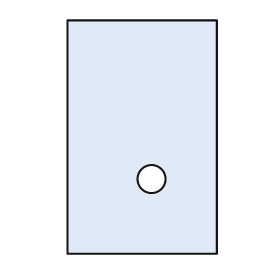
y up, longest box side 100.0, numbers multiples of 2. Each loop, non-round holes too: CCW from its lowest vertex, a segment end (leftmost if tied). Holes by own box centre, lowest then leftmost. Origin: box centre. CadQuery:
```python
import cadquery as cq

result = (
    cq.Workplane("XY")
    .moveTo(-32.0, -50.0)
    .lineTo(32.0, -50.0)
    .lineTo(32.0, 50.0)
    .lineTo(-32.0, 50.0)
    .close()
    .moveTo(4.0, -18.0)
    .circle(6.0)
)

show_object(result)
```